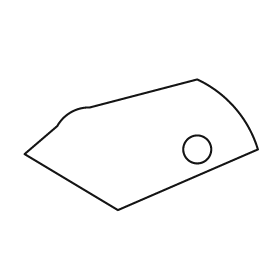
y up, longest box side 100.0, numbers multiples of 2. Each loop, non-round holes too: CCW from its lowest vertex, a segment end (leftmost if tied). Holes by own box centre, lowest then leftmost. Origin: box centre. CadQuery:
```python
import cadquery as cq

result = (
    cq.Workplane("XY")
    .moveTo(-10.0, -28.0)
    .lineTo(50.0, -2.0)
    .threePointArc((40.0, 16.0), (24.0, 28.0))
    .lineTo(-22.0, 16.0)
    .threePointArc((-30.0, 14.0), (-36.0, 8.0))
    .lineTo(-50.0, -4.0)
    .close()
    .moveTo(24.0, -2.0)
    .circle(6.0)
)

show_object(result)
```